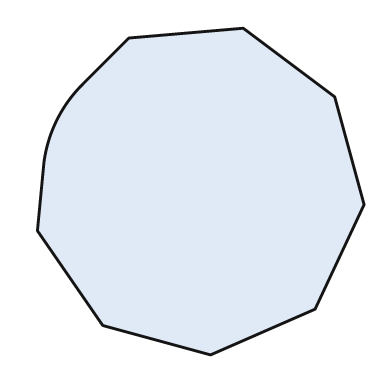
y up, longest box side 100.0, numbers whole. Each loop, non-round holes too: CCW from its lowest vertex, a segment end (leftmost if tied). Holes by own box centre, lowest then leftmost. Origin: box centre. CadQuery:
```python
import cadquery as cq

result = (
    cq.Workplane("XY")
    .moveTo(3.0, -50.0)
    .lineTo(35.0, -36.0)
    .lineTo(50.0, -4.0)
    .lineTo(41.0, 29.0)
    .lineTo(13.0, 50.0)
    .lineTo(-22.0, 47.0)
    .lineTo(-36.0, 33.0)
    .threePointArc((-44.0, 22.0), (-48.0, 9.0))
    .lineTo(-50.0, -12.0)
    .lineTo(-30.0, -41.0)
    .close()
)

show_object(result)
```